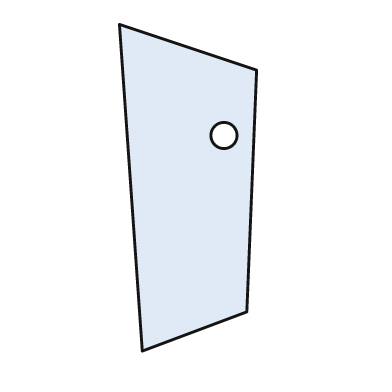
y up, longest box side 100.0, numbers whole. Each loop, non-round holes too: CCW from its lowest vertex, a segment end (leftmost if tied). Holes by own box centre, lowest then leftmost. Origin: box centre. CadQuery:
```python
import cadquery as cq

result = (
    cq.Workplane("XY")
    .moveTo(-14.0, -50.0)
    .lineTo(18.0, -38.0)
    .lineTo(21.0, 36.0)
    .lineTo(-21.0, 50.0)
    .close()
    .moveTo(11.0, 16.0)
    .circle(4.0)
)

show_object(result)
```